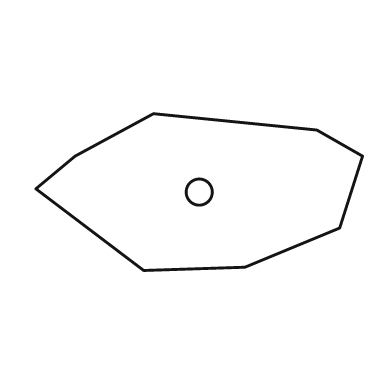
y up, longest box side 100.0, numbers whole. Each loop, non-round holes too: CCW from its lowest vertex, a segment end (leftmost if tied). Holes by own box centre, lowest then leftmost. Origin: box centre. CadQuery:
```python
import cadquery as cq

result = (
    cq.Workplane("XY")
    .moveTo(-17.0, -24.0)
    .lineTo(14.0, -23.0)
    .lineTo(43.0, -11.0)
    .lineTo(50.0, 11.0)
    .lineTo(36.0, 19.0)
    .lineTo(-14.0, 24.0)
    .lineTo(-38.0, 11.0)
    .lineTo(-50.0, 1.0)
    .close()
    .moveTo(0.0, 0.0)
    .circle(4.0)
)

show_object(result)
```